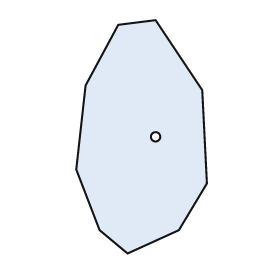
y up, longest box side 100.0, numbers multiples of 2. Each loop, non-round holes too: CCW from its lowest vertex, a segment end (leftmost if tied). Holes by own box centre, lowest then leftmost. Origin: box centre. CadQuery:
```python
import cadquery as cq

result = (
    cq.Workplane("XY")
    .moveTo(-6.0, -50.0)
    .lineTo(16.0, -40.0)
    .lineTo(28.0, -20.0)
    .lineTo(26.0, 20.0)
    .lineTo(6.0, 50.0)
    .lineTo(-10.0, 48.0)
    .lineTo(-24.0, 22.0)
    .lineTo(-28.0, -14.0)
    .lineTo(-18.0, -40.0)
    .close()
    .moveTo(6.0, 0.0)
    .circle(2.0)
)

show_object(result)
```